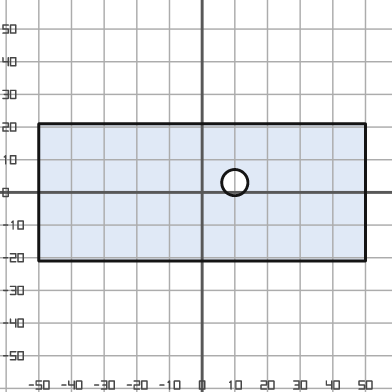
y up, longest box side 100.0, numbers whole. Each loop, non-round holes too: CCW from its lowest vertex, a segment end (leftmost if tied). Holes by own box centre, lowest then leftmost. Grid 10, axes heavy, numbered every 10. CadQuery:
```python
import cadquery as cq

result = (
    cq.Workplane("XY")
    .moveTo(-50.0, -21.0)
    .lineTo(50.0, -21.0)
    .lineTo(50.0, 21.0)
    .lineTo(-50.0, 21.0)
    .close()
    .moveTo(10.0, 3.0)
    .circle(4.0)
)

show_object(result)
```